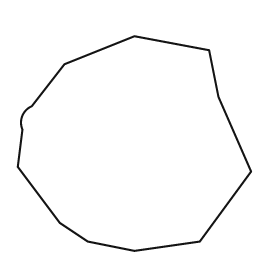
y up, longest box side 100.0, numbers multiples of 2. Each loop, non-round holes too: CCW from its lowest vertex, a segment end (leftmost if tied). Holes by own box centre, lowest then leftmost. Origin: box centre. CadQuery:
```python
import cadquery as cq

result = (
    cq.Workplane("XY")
    .moveTo(0.0, -46.0)
    .lineTo(28.0, -42.0)
    .lineTo(50.0, -12.0)
    .lineTo(36.0, 20.0)
    .lineTo(32.0, 40.0)
    .lineTo(0.0, 46.0)
    .lineTo(-30.0, 34.0)
    .lineTo(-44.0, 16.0)
    .threePointArc((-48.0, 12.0), (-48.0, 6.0))
    .lineTo(-50.0, -10.0)
    .lineTo(-32.0, -34.0)
    .lineTo(-20.0, -42.0)
    .close()
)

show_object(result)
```